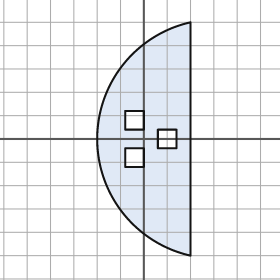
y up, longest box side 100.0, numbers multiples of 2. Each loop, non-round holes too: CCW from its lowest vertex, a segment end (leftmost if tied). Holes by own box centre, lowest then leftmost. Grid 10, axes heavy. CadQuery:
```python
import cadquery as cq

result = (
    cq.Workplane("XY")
    .moveTo(20.0, -50.0)
    .lineTo(20.0, 50.0)
    .threePointArc((-20.0, 0.0), (20.0, -50.0))
    .close()
    .moveTo(-8.0, -12.0)
    .lineTo(0.0, -12.0)
    .lineTo(0.0, -4.0)
    .lineTo(-8.0, -4.0)
    .close()
    .moveTo(6.0, -4.0)
    .lineTo(14.0, -4.0)
    .lineTo(14.0, 4.0)
    .lineTo(6.0, 4.0)
    .close()
    .moveTo(-8.0, 4.0)
    .lineTo(0.0, 4.0)
    .lineTo(0.0, 12.0)
    .lineTo(-8.0, 12.0)
    .close()
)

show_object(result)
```